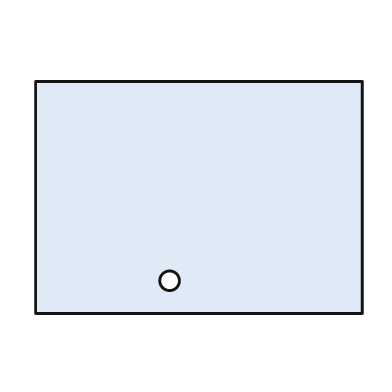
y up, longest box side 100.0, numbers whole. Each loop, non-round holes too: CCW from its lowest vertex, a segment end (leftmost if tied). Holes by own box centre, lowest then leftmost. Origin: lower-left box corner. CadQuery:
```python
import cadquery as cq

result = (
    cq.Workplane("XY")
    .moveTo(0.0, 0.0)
    .lineTo(100.0, 0.0)
    .lineTo(100.0, 71.0)
    .lineTo(0.0, 71.0)
    .close()
    .moveTo(41.0, 10.0)
    .circle(3.0)
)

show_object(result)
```